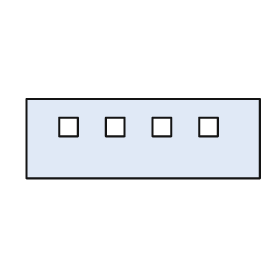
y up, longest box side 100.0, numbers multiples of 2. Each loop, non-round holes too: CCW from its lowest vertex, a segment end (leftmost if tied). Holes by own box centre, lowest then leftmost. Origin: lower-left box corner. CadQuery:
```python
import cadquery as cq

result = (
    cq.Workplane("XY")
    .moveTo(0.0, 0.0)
    .lineTo(100.0, 0.0)
    .lineTo(100.0, 34.0)
    .lineTo(0.0, 34.0)
    .close()
    .moveTo(14.0, 18.0)
    .lineTo(22.0, 18.0)
    .lineTo(22.0, 26.0)
    .lineTo(14.0, 26.0)
    .close()
    .moveTo(34.0, 18.0)
    .lineTo(42.0, 18.0)
    .lineTo(42.0, 26.0)
    .lineTo(34.0, 26.0)
    .close()
    .moveTo(54.0, 18.0)
    .lineTo(62.0, 18.0)
    .lineTo(62.0, 26.0)
    .lineTo(54.0, 26.0)
    .close()
    .moveTo(74.0, 18.0)
    .lineTo(82.0, 18.0)
    .lineTo(82.0, 26.0)
    .lineTo(74.0, 26.0)
    .close()
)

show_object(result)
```